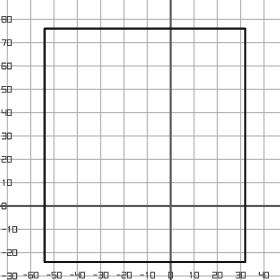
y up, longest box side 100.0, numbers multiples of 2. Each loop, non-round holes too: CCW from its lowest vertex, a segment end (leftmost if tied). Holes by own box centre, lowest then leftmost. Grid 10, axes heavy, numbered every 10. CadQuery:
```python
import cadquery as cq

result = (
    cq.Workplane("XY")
    .moveTo(-54.0, -24.0)
    .lineTo(32.0, -24.0)
    .lineTo(32.0, 76.0)
    .lineTo(-54.0, 76.0)
    .close()
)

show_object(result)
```